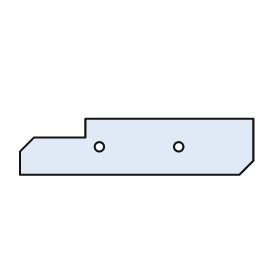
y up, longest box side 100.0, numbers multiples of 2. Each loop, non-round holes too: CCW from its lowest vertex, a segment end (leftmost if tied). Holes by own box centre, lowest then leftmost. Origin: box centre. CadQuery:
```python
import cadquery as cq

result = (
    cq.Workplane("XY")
    .moveTo(-50.0, -12.0)
    .lineTo(44.0, -12.0)
    .lineTo(50.0, -6.0)
    .lineTo(50.0, 12.0)
    .lineTo(-22.0, 12.0)
    .lineTo(-22.0, 4.0)
    .lineTo(-44.0, 4.0)
    .lineTo(-50.0, -2.0)
    .close()
    .moveTo(-16.0, 0.0)
    .circle(2.0)
    .moveTo(18.0, 0.0)
    .circle(2.0)
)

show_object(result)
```